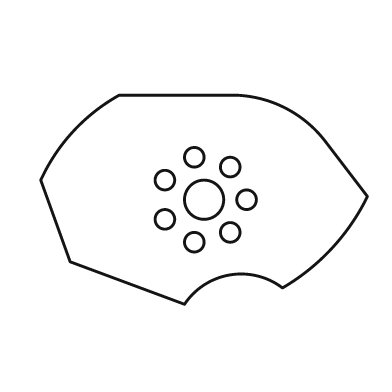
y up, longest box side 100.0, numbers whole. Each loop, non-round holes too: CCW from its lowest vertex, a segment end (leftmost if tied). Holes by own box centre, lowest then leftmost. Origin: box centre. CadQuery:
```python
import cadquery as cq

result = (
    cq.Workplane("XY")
    .moveTo(-6.0, -32.0)
    .threePointArc((8.0, -23.0), (24.0, -27.0))
    .threePointArc((39.0, -15.0), (50.0, 1.0))
    .lineTo(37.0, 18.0)
    .threePointArc((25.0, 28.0), (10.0, 32.0))
    .lineTo(-26.0, 32.0)
    .threePointArc((-40.0, 21.0), (-50.0, 6.0))
    .lineTo(-41.0, -19.0)
    .close()
    .moveTo(-3.0, -13.0)
    .circle(3.0)
    .moveTo(8.0, -10.0)
    .circle(3.0)
    .moveTo(-12.0, -6.0)
    .circle(3.0)
    .moveTo(0.0, 0.0)
    .circle(6.0)
    .moveTo(13.0, 0.0)
    .circle(3.0)
    .moveTo(-12.0, 6.0)
    .circle(3.0)
    .moveTo(8.0, 10.0)
    .circle(3.0)
    .moveTo(-3.0, 13.0)
    .circle(3.0)
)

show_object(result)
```